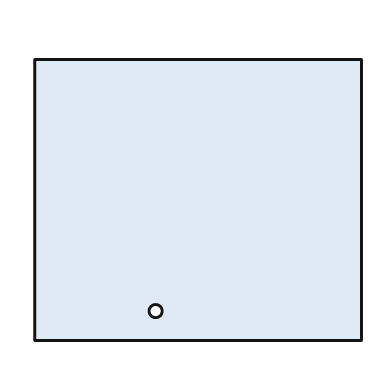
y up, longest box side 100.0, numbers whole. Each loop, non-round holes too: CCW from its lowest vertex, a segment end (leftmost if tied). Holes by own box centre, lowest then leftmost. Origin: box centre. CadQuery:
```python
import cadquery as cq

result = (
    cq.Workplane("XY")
    .moveTo(-50.0, -43.0)
    .lineTo(50.0, -43.0)
    .lineTo(50.0, 43.0)
    .lineTo(-50.0, 43.0)
    .close()
    .moveTo(-13.0, -34.0)
    .circle(2.0)
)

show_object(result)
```